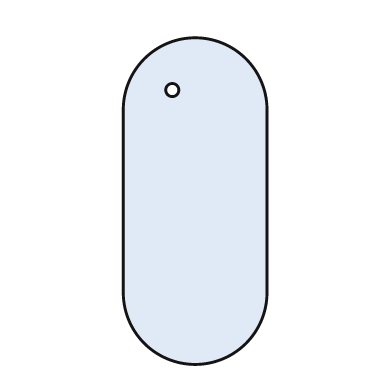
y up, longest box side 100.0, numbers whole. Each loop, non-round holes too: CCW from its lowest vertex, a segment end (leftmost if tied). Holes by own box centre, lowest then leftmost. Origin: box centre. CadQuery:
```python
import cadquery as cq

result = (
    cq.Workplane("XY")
    .moveTo(-22.0, -28.0)
    .threePointArc((0.0, -50.0), (22.0, -28.0))
    .lineTo(22.0, 28.0)
    .threePointArc((0.0, 50.0), (-22.0, 28.0))
    .close()
    .moveTo(-7.0, 34.0)
    .circle(2.0)
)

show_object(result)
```